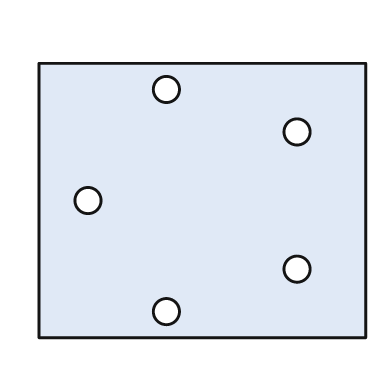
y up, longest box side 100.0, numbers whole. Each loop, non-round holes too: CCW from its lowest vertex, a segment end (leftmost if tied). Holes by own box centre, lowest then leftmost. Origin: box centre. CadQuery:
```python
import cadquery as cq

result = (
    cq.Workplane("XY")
    .moveTo(-50.0, -42.0)
    .lineTo(50.0, -42.0)
    .lineTo(50.0, 42.0)
    .lineTo(-50.0, 42.0)
    .close()
    .moveTo(-11.0, -34.0)
    .circle(4.0)
    .moveTo(29.0, -21.0)
    .circle(4.0)
    .moveTo(-35.0, 0.0)
    .circle(4.0)
    .moveTo(29.0, 21.0)
    .circle(4.0)
    .moveTo(-11.0, 34.0)
    .circle(4.0)
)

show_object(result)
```